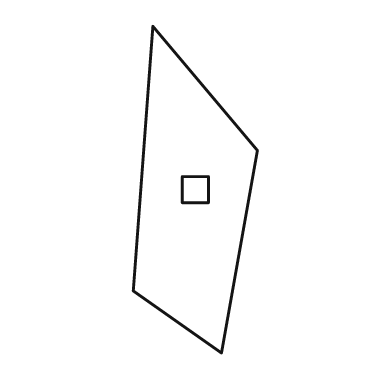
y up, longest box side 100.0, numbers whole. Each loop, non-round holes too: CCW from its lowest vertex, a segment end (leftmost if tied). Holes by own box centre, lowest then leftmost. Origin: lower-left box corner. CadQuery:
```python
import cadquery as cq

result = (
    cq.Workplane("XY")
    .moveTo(27.0, 0.0)
    .lineTo(38.0, 62.0)
    .lineTo(6.0, 100.0)
    .lineTo(0.0, 19.0)
    .close()
    .moveTo(15.0, 46.0)
    .lineTo(23.0, 46.0)
    .lineTo(23.0, 54.0)
    .lineTo(15.0, 54.0)
    .close()
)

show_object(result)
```